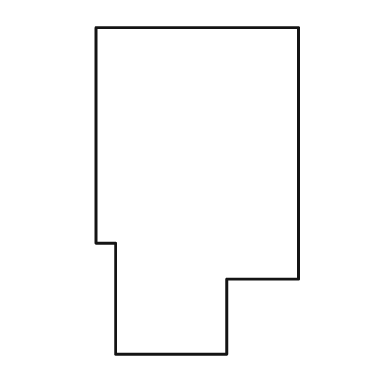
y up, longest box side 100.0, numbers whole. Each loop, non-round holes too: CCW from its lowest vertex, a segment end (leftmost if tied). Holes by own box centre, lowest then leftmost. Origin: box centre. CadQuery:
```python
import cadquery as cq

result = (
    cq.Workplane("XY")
    .moveTo(-25.0, -50.0)
    .lineTo(9.0, -50.0)
    .lineTo(9.0, -27.0)
    .lineTo(31.0, -27.0)
    .lineTo(31.0, 50.0)
    .lineTo(-31.0, 50.0)
    .lineTo(-31.0, -16.0)
    .lineTo(-25.0, -16.0)
    .close()
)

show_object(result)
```